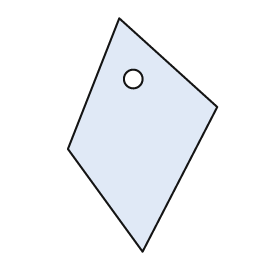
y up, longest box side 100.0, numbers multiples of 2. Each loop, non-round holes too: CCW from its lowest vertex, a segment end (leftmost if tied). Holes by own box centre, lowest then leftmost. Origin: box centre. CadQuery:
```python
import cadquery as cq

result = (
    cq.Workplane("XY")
    .moveTo(0.0, -50.0)
    .lineTo(32.0, 12.0)
    .lineTo(-10.0, 50.0)
    .lineTo(-32.0, -6.0)
    .close()
    .moveTo(-4.0, 24.0)
    .circle(4.0)
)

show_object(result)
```